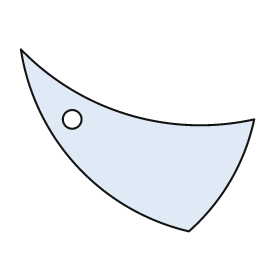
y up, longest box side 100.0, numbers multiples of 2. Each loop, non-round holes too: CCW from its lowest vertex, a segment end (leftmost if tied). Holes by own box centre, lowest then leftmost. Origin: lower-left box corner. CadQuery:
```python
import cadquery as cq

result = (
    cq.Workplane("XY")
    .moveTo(72.0, 0.0)
    .threePointArc((90.0, 22.0), (100.0, 48.0))
    .threePointArc((46.0, 50.0), (0.0, 78.0))
    .threePointArc((24.0, 28.0), (72.0, 0.0))
    .close()
    .moveTo(22.0, 48.0)
    .circle(4.0)
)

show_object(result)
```